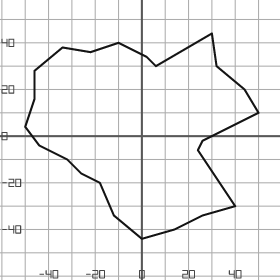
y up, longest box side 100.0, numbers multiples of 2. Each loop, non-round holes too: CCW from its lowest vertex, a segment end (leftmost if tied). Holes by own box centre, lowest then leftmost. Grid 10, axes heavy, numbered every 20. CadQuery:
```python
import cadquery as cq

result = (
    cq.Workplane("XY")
    .moveTo(0.0, -44.0)
    .lineTo(14.0, -40.0)
    .lineTo(26.0, -34.0)
    .lineTo(40.0, -30.0)
    .lineTo(24.0, -6.0)
    .lineTo(26.0, -2.0)
    .lineTo(50.0, 10.0)
    .lineTo(44.0, 20.0)
    .lineTo(32.0, 30.0)
    .lineTo(30.0, 44.0)
    .lineTo(6.0, 30.0)
    .lineTo(2.0, 34.0)
    .lineTo(-10.0, 40.0)
    .lineTo(-22.0, 36.0)
    .lineTo(-34.0, 38.0)
    .lineTo(-46.0, 28.0)
    .lineTo(-46.0, 16.0)
    .lineTo(-50.0, 4.0)
    .lineTo(-44.0, -4.0)
    .lineTo(-32.0, -10.0)
    .lineTo(-26.0, -16.0)
    .lineTo(-18.0, -20.0)
    .lineTo(-12.0, -34.0)
    .close()
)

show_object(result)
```